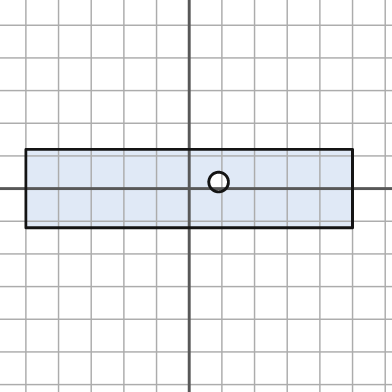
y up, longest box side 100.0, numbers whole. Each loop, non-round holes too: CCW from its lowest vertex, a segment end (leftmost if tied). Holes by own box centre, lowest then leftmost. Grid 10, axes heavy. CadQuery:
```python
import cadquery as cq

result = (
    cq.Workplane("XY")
    .moveTo(-50.0, -12.0)
    .lineTo(50.0, -12.0)
    .lineTo(50.0, 12.0)
    .lineTo(-50.0, 12.0)
    .close()
    .moveTo(9.0, 2.0)
    .circle(3.0)
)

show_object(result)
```